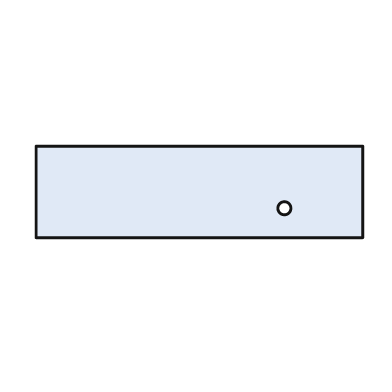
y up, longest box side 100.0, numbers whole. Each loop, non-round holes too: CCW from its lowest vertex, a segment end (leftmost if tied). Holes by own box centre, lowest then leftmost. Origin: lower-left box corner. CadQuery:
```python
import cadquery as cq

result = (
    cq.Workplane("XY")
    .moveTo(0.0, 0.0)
    .lineTo(100.0, 0.0)
    .lineTo(100.0, 28.0)
    .lineTo(0.0, 28.0)
    .close()
    .moveTo(76.0, 9.0)
    .circle(2.0)
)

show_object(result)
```